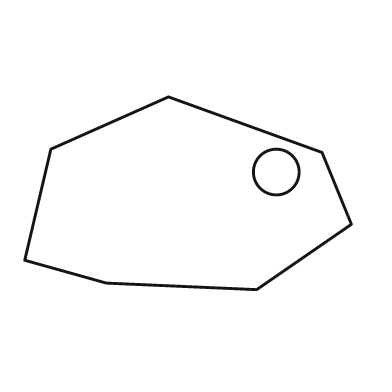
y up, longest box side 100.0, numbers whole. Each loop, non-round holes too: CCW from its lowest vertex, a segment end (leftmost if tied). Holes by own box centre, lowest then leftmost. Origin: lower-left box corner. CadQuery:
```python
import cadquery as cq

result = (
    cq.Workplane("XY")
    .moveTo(71.0, 0.0)
    .lineTo(100.0, 20.0)
    .lineTo(91.0, 42.0)
    .lineTo(44.0, 59.0)
    .lineTo(8.0, 43.0)
    .lineTo(0.0, 9.0)
    .lineTo(25.0, 2.0)
    .close()
    .moveTo(77.0, 36.0)
    .circle(7.0)
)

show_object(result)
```